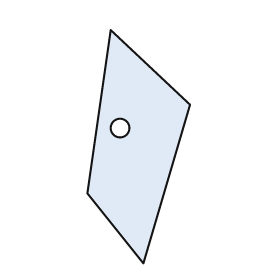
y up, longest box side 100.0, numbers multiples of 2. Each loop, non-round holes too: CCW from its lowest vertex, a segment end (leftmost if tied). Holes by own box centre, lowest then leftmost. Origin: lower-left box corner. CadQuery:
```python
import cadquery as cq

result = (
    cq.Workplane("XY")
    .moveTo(24.0, 0.0)
    .lineTo(44.0, 68.0)
    .lineTo(10.0, 100.0)
    .lineTo(0.0, 30.0)
    .close()
    .moveTo(14.0, 58.0)
    .circle(4.0)
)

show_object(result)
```